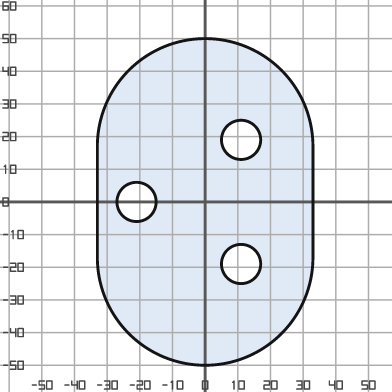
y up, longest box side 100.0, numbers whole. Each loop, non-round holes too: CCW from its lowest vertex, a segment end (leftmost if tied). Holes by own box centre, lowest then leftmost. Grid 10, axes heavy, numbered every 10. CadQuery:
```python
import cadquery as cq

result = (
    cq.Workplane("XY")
    .moveTo(-33.0, -17.0)
    .threePointArc((0.0, -50.0), (33.0, -17.0))
    .lineTo(33.0, 17.0)
    .threePointArc((0.0, 50.0), (-33.0, 17.0))
    .close()
    .moveTo(11.0, -19.0)
    .circle(6.0)
    .moveTo(-21.0, 0.0)
    .circle(6.0)
    .moveTo(11.0, 19.0)
    .circle(6.0)
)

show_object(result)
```